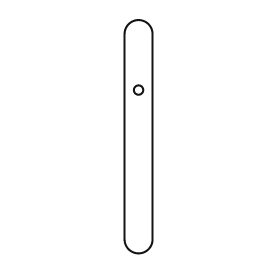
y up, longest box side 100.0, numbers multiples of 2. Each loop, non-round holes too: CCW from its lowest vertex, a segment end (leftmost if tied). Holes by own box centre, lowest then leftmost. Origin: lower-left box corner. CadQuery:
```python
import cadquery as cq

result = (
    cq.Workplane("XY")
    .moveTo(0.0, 6.0)
    .threePointArc((6.0, 0.0), (12.0, 6.0))
    .lineTo(12.0, 94.0)
    .threePointArc((6.0, 100.0), (0.0, 94.0))
    .close()
    .moveTo(6.0, 70.0)
    .circle(2.0)
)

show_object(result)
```